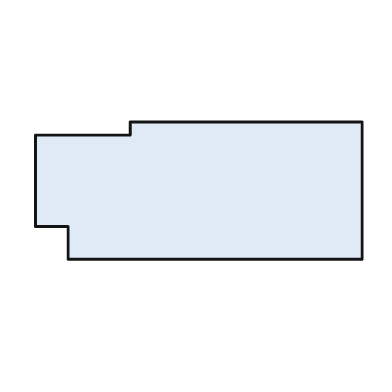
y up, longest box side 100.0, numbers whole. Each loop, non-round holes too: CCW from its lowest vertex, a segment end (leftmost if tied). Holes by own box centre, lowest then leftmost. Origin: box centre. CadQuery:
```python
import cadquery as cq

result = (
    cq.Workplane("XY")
    .moveTo(-40.0, -21.0)
    .lineTo(50.0, -21.0)
    .lineTo(50.0, 21.0)
    .lineTo(-21.0, 21.0)
    .lineTo(-21.0, 17.0)
    .lineTo(-50.0, 17.0)
    .lineTo(-50.0, -11.0)
    .lineTo(-40.0, -11.0)
    .close()
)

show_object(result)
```